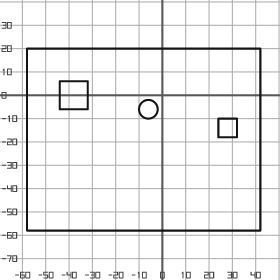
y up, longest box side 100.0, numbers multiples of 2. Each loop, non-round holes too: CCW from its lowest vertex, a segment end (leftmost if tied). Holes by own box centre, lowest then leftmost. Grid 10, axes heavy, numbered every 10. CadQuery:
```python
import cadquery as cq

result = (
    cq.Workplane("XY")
    .moveTo(-58.0, -58.0)
    .lineTo(42.0, -58.0)
    .lineTo(42.0, 20.0)
    .lineTo(-58.0, 20.0)
    .close()
    .moveTo(24.0, -18.0)
    .lineTo(32.0, -18.0)
    .lineTo(32.0, -10.0)
    .lineTo(24.0, -10.0)
    .close()
    .moveTo(-6.0, -6.0)
    .circle(4.0)
    .moveTo(-44.0, -6.0)
    .lineTo(-32.0, -6.0)
    .lineTo(-32.0, 6.0)
    .lineTo(-44.0, 6.0)
    .close()
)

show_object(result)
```